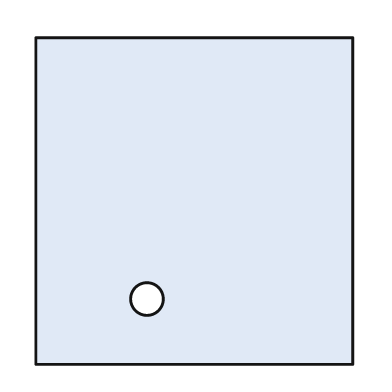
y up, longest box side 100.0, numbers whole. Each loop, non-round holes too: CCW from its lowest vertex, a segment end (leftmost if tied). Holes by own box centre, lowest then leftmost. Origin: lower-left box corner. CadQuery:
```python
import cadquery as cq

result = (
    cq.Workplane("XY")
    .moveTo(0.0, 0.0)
    .lineTo(97.0, 0.0)
    .lineTo(97.0, 100.0)
    .lineTo(0.0, 100.0)
    .close()
    .moveTo(34.0, 20.0)
    .circle(5.0)
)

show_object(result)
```